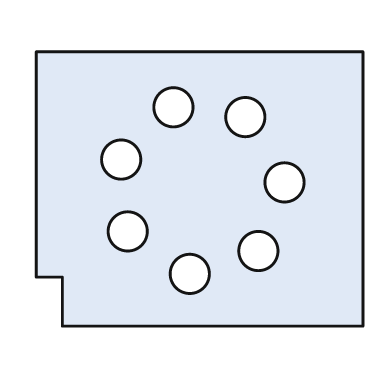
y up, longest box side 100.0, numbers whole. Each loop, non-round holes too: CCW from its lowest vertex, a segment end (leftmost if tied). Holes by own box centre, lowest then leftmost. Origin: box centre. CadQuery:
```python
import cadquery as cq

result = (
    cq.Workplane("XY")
    .moveTo(-42.0, -42.0)
    .lineTo(50.0, -42.0)
    .lineTo(50.0, 42.0)
    .lineTo(-50.0, 42.0)
    .lineTo(-50.0, -27.0)
    .lineTo(-42.0, -27.0)
    .close()
    .moveTo(-3.0, -26.0)
    .circle(6.0)
    .moveTo(18.0, -19.0)
    .circle(6.0)
    .moveTo(-22.0, -13.0)
    .circle(6.0)
    .moveTo(26.0, 2.0)
    .circle(6.0)
    .moveTo(-24.0, 9.0)
    .circle(6.0)
    .moveTo(14.0, 22.0)
    .circle(6.0)
    .moveTo(-8.0, 25.0)
    .circle(6.0)
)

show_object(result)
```